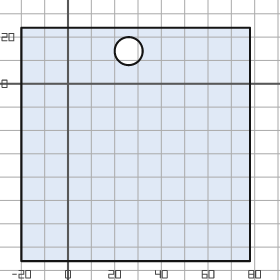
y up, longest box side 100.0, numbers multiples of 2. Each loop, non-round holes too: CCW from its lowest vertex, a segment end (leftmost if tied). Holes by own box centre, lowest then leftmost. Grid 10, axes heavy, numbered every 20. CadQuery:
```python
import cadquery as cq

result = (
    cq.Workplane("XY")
    .moveTo(-20.0, -76.0)
    .lineTo(78.0, -76.0)
    .lineTo(78.0, 24.0)
    .lineTo(-20.0, 24.0)
    .close()
    .moveTo(26.0, 14.0)
    .circle(6.0)
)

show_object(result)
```